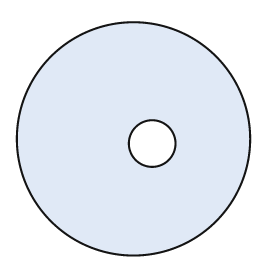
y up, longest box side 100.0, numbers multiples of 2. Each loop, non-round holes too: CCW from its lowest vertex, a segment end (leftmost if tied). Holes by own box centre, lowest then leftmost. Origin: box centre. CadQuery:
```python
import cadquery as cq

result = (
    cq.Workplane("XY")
    .moveTo(0.0, 0.0)
    .circle(50.0)
    .moveTo(8.0, -2.0)
    .circle(10.0)
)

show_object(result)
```